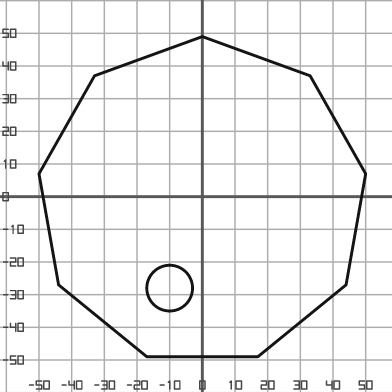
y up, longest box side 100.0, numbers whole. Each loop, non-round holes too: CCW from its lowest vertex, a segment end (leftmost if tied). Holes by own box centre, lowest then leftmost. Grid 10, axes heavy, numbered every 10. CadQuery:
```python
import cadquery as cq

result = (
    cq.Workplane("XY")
    .moveTo(-17.0, -49.0)
    .lineTo(17.0, -49.0)
    .lineTo(44.0, -27.0)
    .lineTo(50.0, 7.0)
    .lineTo(33.0, 37.0)
    .lineTo(0.0, 49.0)
    .lineTo(-33.0, 37.0)
    .lineTo(-50.0, 7.0)
    .lineTo(-44.0, -27.0)
    .close()
    .moveTo(-10.0, -28.0)
    .circle(7.0)
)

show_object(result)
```